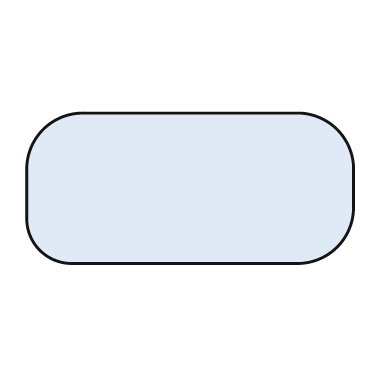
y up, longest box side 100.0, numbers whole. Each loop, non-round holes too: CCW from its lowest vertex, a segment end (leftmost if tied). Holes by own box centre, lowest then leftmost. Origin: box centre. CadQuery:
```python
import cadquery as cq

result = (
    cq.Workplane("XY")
    .moveTo(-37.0, -23.0)
    .lineTo(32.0, -23.0)
    .threePointArc((45.0, -18.0), (50.0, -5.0))
    .lineTo(50.0, 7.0)
    .threePointArc((45.0, 18.0), (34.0, 23.0))
    .lineTo(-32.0, 23.0)
    .threePointArc((-45.0, 18.0), (-50.0, 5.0))
    .lineTo(-50.0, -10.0)
    .threePointArc((-46.0, -19.0), (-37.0, -23.0))
    .close()
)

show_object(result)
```